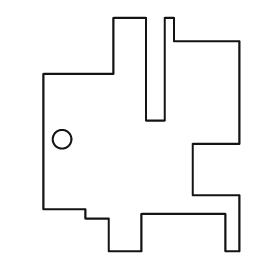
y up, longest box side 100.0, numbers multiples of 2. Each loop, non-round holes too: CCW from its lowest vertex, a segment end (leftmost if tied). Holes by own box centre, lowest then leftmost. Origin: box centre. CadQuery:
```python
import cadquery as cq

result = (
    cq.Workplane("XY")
    .moveTo(-14.0, -50.0)
    .lineTo(0.0, -50.0)
    .lineTo(0.0, -34.0)
    .lineTo(36.0, -34.0)
    .lineTo(36.0, -50.0)
    .lineTo(42.0, -50.0)
    .lineTo(42.0, -26.0)
    .lineTo(22.0, -26.0)
    .lineTo(22.0, -4.0)
    .lineTo(42.0, -4.0)
    .lineTo(42.0, 40.0)
    .lineTo(14.0, 40.0)
    .lineTo(14.0, 50.0)
    .lineTo(10.0, 50.0)
    .lineTo(10.0, 6.0)
    .lineTo(2.0, 6.0)
    .lineTo(2.0, 50.0)
    .lineTo(-12.0, 50.0)
    .lineTo(-12.0, 26.0)
    .lineTo(-42.0, 26.0)
    .lineTo(-42.0, -32.0)
    .lineTo(-24.0, -32.0)
    .lineTo(-24.0, -36.0)
    .lineTo(-14.0, -36.0)
    .close()
    .moveTo(-34.0, -2.0)
    .circle(4.0)
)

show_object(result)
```